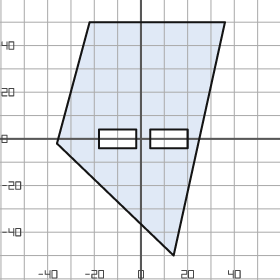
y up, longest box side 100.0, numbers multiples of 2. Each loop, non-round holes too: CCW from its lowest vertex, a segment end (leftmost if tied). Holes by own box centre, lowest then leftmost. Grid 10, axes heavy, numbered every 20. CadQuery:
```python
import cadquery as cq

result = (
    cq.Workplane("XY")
    .moveTo(14.0, -50.0)
    .lineTo(36.0, 50.0)
    .lineTo(-22.0, 50.0)
    .lineTo(-36.0, -2.0)
    .close()
    .moveTo(-18.0, -4.0)
    .lineTo(-2.0, -4.0)
    .lineTo(-2.0, 4.0)
    .lineTo(-18.0, 4.0)
    .close()
    .moveTo(4.0, -4.0)
    .lineTo(20.0, -4.0)
    .lineTo(20.0, 4.0)
    .lineTo(4.0, 4.0)
    .close()
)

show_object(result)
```